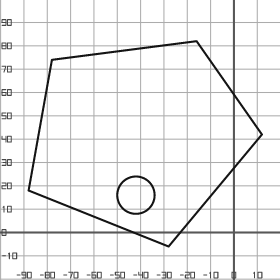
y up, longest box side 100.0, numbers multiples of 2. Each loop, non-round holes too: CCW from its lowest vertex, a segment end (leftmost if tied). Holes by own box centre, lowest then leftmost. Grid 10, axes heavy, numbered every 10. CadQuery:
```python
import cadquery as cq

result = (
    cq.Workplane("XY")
    .moveTo(-28.0, -6.0)
    .lineTo(12.0, 42.0)
    .lineTo(-16.0, 82.0)
    .lineTo(-78.0, 74.0)
    .lineTo(-88.0, 18.0)
    .close()
    .moveTo(-42.0, 16.0)
    .circle(8.0)
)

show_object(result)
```